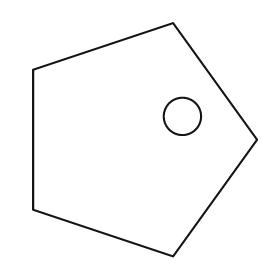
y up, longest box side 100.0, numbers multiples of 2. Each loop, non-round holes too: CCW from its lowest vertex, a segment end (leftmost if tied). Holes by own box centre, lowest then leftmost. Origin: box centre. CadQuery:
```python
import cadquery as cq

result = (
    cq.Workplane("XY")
    .moveTo(12.0, -50.0)
    .lineTo(48.0, 0.0)
    .lineTo(12.0, 50.0)
    .lineTo(-48.0, 30.0)
    .lineTo(-48.0, -30.0)
    .close()
    .moveTo(16.0, 10.0)
    .circle(8.0)
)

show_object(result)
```